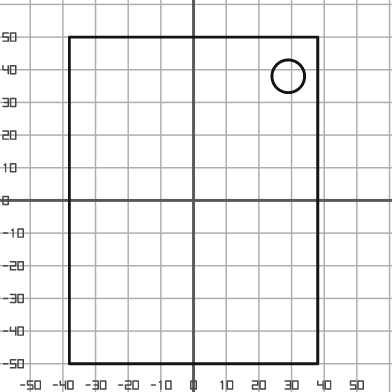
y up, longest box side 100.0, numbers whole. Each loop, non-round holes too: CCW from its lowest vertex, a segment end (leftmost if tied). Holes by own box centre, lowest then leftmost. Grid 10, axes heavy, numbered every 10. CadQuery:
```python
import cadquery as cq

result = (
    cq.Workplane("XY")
    .moveTo(-38.0, -50.0)
    .lineTo(38.0, -50.0)
    .lineTo(38.0, 50.0)
    .lineTo(-38.0, 50.0)
    .close()
    .moveTo(29.0, 38.0)
    .circle(5.0)
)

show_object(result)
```